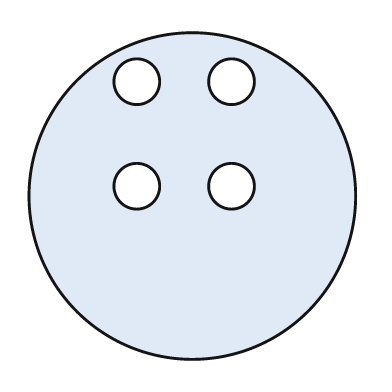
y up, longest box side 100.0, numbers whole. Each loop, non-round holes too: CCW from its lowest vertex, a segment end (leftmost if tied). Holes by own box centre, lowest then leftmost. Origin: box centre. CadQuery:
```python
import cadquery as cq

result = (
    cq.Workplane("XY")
    .moveTo(0.0, 0.0)
    .circle(50.0)
    .moveTo(-17.0, 3.0)
    .circle(7.0)
    .moveTo(12.0, 3.0)
    .circle(7.0)
    .moveTo(-17.0, 35.0)
    .circle(7.0)
    .moveTo(12.0, 35.0)
    .circle(7.0)
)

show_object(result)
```